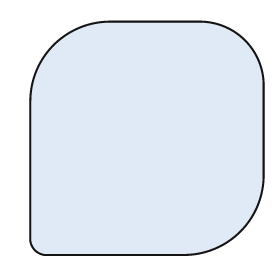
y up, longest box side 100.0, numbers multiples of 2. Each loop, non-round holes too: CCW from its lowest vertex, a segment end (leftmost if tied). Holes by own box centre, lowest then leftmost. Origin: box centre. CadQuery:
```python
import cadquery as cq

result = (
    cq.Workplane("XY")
    .moveTo(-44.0, -50.0)
    .lineTo(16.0, -50.0)
    .threePointArc((40.0, -40.0), (50.0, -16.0))
    .lineTo(50.0, 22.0)
    .threePointArc((42.0, 42.0), (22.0, 50.0))
    .lineTo(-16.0, 50.0)
    .threePointArc((-40.0, 40.0), (-50.0, 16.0))
    .lineTo(-50.0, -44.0)
    .threePointArc((-48.0, -48.0), (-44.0, -50.0))
    .close()
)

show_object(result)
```